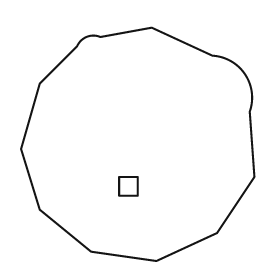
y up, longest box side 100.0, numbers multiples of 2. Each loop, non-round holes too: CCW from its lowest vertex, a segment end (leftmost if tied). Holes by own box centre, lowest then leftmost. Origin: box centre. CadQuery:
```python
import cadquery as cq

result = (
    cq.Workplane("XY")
    .moveTo(8.0, -50.0)
    .lineTo(34.0, -38.0)
    .lineTo(50.0, -14.0)
    .lineTo(48.0, 14.0)
    .threePointArc((46.0, 30.0), (32.0, 38.0))
    .lineTo(6.0, 50.0)
    .lineTo(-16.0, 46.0)
    .threePointArc((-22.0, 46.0), (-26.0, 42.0))
    .lineTo(-42.0, 26.0)
    .lineTo(-50.0, -2.0)
    .lineTo(-42.0, -28.0)
    .lineTo(-20.0, -46.0)
    .close()
    .moveTo(-8.0, -22.0)
    .lineTo(0.0, -22.0)
    .lineTo(0.0, -14.0)
    .lineTo(-8.0, -14.0)
    .close()
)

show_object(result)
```